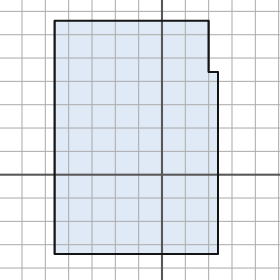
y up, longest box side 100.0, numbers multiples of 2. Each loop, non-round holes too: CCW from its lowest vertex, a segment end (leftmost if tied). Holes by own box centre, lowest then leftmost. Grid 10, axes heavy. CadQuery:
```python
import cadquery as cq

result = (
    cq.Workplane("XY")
    .moveTo(-46.0, -34.0)
    .lineTo(24.0, -34.0)
    .lineTo(24.0, 44.0)
    .lineTo(20.0, 44.0)
    .lineTo(20.0, 66.0)
    .lineTo(-46.0, 66.0)
    .close()
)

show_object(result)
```